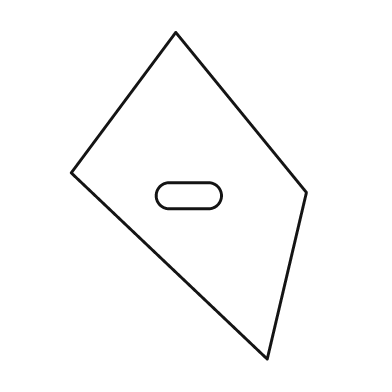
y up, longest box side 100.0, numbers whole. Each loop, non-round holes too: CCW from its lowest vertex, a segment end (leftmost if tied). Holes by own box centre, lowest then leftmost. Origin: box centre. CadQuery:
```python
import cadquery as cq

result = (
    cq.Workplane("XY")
    .moveTo(24.0, -50.0)
    .lineTo(36.0, 1.0)
    .lineTo(-4.0, 50.0)
    .lineTo(-36.0, 7.0)
    .close()
    .moveTo(-6.0, -4.0)
    .lineTo(6.0, -4.0)
    .threePointArc((10.0, 0.0), (6.0, 4.0))
    .lineTo(-6.0, 4.0)
    .threePointArc((-10.0, 0.0), (-6.0, -4.0))
    .close()
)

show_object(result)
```